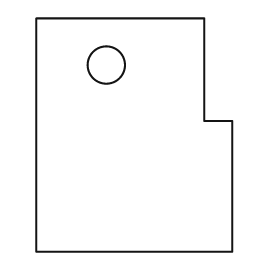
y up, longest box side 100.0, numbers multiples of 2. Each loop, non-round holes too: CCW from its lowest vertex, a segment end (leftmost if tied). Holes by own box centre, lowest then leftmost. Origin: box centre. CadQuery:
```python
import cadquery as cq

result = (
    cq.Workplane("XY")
    .moveTo(-42.0, -50.0)
    .lineTo(42.0, -50.0)
    .lineTo(42.0, 6.0)
    .lineTo(30.0, 6.0)
    .lineTo(30.0, 50.0)
    .lineTo(-42.0, 50.0)
    .close()
    .moveTo(-12.0, 30.0)
    .circle(8.0)
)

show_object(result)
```